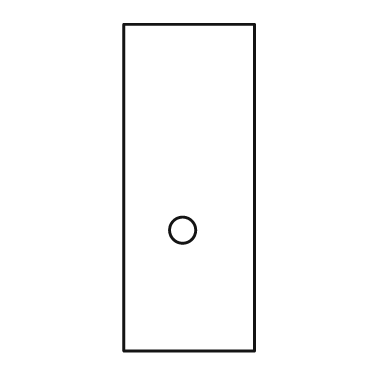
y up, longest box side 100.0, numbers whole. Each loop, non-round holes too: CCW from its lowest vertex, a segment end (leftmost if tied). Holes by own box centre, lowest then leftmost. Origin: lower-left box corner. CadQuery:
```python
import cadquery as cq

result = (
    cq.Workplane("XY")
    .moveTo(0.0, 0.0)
    .lineTo(40.0, 0.0)
    .lineTo(40.0, 100.0)
    .lineTo(0.0, 100.0)
    .close()
    .moveTo(18.0, 37.0)
    .circle(4.0)
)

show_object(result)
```